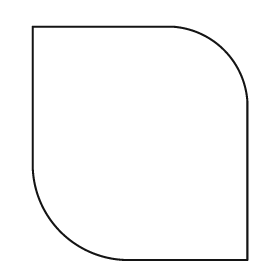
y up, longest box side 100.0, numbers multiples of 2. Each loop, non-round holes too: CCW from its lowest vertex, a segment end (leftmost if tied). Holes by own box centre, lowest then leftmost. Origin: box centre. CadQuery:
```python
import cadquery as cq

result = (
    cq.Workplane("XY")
    .moveTo(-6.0, -50.0)
    .lineTo(46.0, -50.0)
    .lineTo(46.0, 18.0)
    .threePointArc((36.0, 40.0), (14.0, 50.0))
    .lineTo(-46.0, 50.0)
    .lineTo(-46.0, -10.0)
    .threePointArc((-34.0, -38.0), (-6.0, -50.0))
    .close()
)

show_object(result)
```